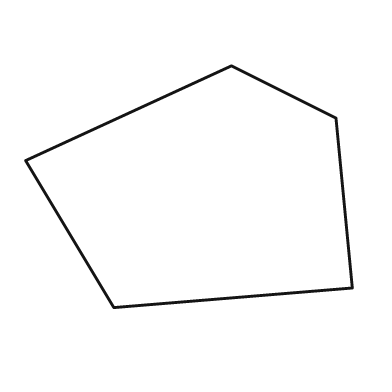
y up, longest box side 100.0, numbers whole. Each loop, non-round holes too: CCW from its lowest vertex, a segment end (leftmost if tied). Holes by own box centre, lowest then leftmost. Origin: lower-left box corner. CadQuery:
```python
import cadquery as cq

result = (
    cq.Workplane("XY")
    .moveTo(27.0, 0.0)
    .lineTo(100.0, 6.0)
    .lineTo(95.0, 58.0)
    .lineTo(63.0, 74.0)
    .lineTo(0.0, 45.0)
    .close()
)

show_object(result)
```